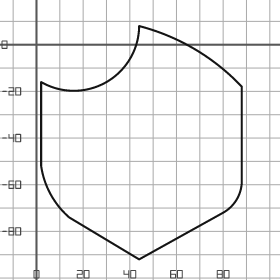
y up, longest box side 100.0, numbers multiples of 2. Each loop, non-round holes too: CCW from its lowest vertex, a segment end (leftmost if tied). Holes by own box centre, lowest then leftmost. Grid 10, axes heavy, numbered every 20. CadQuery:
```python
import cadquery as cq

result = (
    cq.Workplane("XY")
    .moveTo(44.0, -92.0)
    .lineTo(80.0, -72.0)
    .threePointArc((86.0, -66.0), (88.0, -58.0))
    .lineTo(88.0, -18.0)
    .threePointArc((68.0, -2.0), (44.0, 8.0))
    .threePointArc((30.0, -16.0), (2.0, -16.0))
    .lineTo(2.0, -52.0)
    .threePointArc((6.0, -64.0), (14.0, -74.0))
    .close()
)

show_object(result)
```